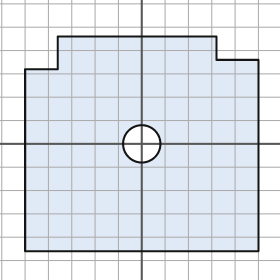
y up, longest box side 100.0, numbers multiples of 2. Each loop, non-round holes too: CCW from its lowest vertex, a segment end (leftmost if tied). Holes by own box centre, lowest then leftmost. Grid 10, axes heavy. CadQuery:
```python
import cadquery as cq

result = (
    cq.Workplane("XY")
    .moveTo(-50.0, -46.0)
    .lineTo(50.0, -46.0)
    .lineTo(50.0, 36.0)
    .lineTo(32.0, 36.0)
    .lineTo(32.0, 46.0)
    .lineTo(-36.0, 46.0)
    .lineTo(-36.0, 32.0)
    .lineTo(-50.0, 32.0)
    .close()
    .moveTo(0.0, 0.0)
    .circle(8.0)
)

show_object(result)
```